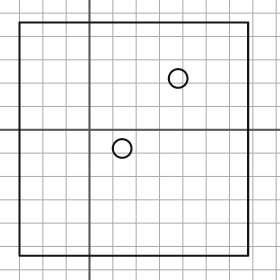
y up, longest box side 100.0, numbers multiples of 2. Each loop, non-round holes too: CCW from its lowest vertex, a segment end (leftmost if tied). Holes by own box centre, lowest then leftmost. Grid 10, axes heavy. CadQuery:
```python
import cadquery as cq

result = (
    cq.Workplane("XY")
    .moveTo(-30.0, -54.0)
    .lineTo(68.0, -54.0)
    .lineTo(68.0, 46.0)
    .lineTo(-30.0, 46.0)
    .close()
    .moveTo(14.0, -8.0)
    .circle(4.0)
    .moveTo(38.0, 22.0)
    .circle(4.0)
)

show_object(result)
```